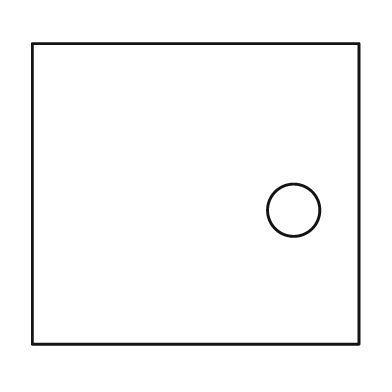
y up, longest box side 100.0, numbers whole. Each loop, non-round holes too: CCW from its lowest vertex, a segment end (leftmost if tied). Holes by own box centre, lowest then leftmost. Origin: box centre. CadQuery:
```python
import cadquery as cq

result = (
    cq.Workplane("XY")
    .moveTo(-50.0, -46.0)
    .lineTo(50.0, -46.0)
    .lineTo(50.0, 46.0)
    .lineTo(-50.0, 46.0)
    .close()
    .moveTo(30.0, -5.0)
    .circle(8.0)
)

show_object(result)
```